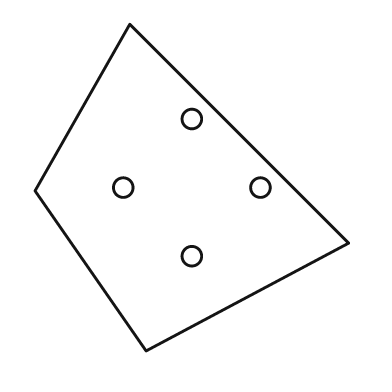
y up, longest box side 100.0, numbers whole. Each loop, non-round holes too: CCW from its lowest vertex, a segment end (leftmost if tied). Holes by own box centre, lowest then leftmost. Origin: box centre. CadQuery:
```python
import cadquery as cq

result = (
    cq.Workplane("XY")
    .moveTo(-14.0, -50.0)
    .lineTo(48.0, -17.0)
    .lineTo(-19.0, 50.0)
    .lineTo(-48.0, -1.0)
    .close()
    .moveTo(0.0, -21.0)
    .circle(3.0)
    .moveTo(-21.0, 0.0)
    .circle(3.0)
    .moveTo(21.0, 0.0)
    .circle(3.0)
    .moveTo(0.0, 21.0)
    .circle(3.0)
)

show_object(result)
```